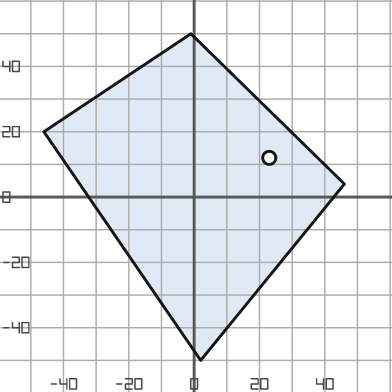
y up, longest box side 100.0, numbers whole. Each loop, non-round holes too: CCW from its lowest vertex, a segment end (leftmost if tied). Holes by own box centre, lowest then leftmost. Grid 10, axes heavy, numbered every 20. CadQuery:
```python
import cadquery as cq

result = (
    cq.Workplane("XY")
    .moveTo(2.0, -50.0)
    .lineTo(46.0, 4.0)
    .lineTo(-1.0, 50.0)
    .lineTo(-46.0, 20.0)
    .close()
    .moveTo(23.0, 12.0)
    .circle(2.0)
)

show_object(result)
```